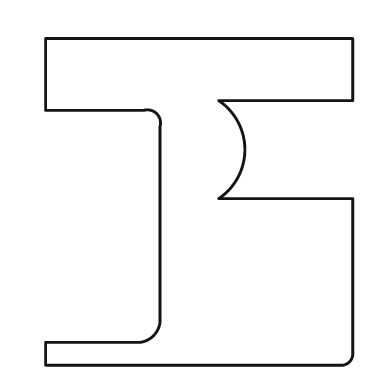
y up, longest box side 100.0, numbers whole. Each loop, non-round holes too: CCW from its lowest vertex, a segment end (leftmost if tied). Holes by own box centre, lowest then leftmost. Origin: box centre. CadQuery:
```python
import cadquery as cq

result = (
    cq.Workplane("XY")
    .moveTo(-47.0, -50.0)
    .lineTo(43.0, -50.0)
    .threePointArc((46.0, -49.0), (47.0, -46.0))
    .lineTo(47.0, 1.0)
    .lineTo(6.0, 1.0)
    .threePointArc((14.0, 16.0), (6.0, 31.0))
    .lineTo(47.0, 31.0)
    .lineTo(47.0, 50.0)
    .lineTo(-47.0, 50.0)
    .lineTo(-47.0, 28.0)
    .lineTo(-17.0, 28.0)
    .threePointArc((-13.0, 27.0), (-12.0, 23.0))
    .lineTo(-12.0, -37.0)
    .threePointArc((-14.0, -41.0), (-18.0, -43.0))
    .lineTo(-47.0, -43.0)
    .close()
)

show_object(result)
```